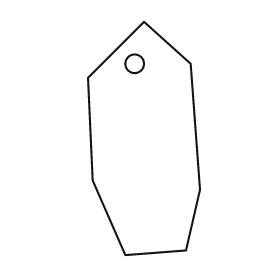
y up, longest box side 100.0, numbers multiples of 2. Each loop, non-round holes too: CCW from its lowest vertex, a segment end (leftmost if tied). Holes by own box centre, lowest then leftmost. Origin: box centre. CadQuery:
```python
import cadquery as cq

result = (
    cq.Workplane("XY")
    .moveTo(-8.0, -50.0)
    .lineTo(18.0, -48.0)
    .lineTo(24.0, -22.0)
    .lineTo(20.0, 32.0)
    .lineTo(0.0, 50.0)
    .lineTo(-24.0, 26.0)
    .lineTo(-22.0, -18.0)
    .close()
    .moveTo(-4.0, 32.0)
    .circle(4.0)
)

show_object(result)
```